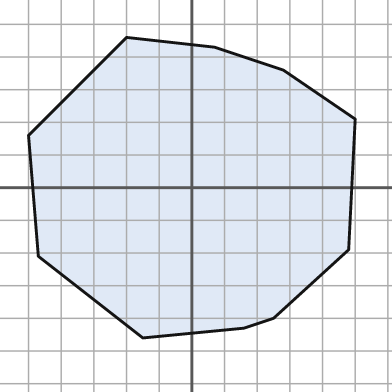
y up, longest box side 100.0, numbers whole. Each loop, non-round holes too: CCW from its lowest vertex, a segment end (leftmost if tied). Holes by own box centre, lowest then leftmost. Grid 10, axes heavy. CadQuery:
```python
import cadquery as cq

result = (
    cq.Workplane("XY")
    .moveTo(-15.0, -46.0)
    .lineTo(16.0, -43.0)
    .lineTo(25.0, -40.0)
    .lineTo(48.0, -19.0)
    .lineTo(50.0, 21.0)
    .lineTo(28.0, 36.0)
    .lineTo(7.0, 43.0)
    .lineTo(-20.0, 46.0)
    .lineTo(-50.0, 16.0)
    .lineTo(-47.0, -21.0)
    .close()
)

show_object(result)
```